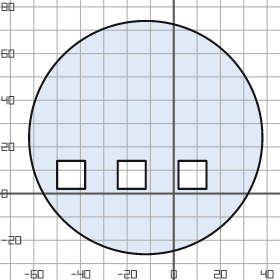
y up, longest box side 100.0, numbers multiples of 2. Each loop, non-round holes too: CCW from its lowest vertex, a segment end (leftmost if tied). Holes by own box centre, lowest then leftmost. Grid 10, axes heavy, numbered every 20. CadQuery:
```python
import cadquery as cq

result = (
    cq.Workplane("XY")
    .moveTo(-12.0, 24.0)
    .circle(50.0)
    .moveTo(-50.0, 2.0)
    .lineTo(-38.0, 2.0)
    .lineTo(-38.0, 14.0)
    .lineTo(-50.0, 14.0)
    .close()
    .moveTo(-24.0, 2.0)
    .lineTo(-12.0, 2.0)
    .lineTo(-12.0, 14.0)
    .lineTo(-24.0, 14.0)
    .close()
    .moveTo(2.0, 2.0)
    .lineTo(14.0, 2.0)
    .lineTo(14.0, 14.0)
    .lineTo(2.0, 14.0)
    .close()
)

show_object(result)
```